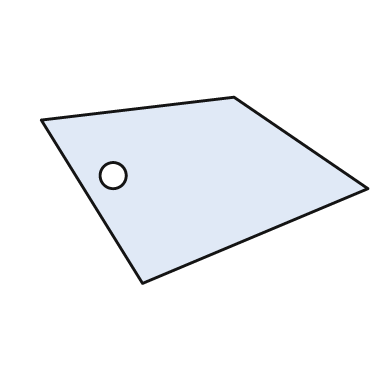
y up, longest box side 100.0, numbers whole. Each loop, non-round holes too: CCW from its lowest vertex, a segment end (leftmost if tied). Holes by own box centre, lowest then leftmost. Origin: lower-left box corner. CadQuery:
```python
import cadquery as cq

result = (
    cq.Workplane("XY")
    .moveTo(31.0, 0.0)
    .lineTo(100.0, 29.0)
    .lineTo(59.0, 57.0)
    .lineTo(0.0, 50.0)
    .close()
    .moveTo(22.0, 33.0)
    .circle(4.0)
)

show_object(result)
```